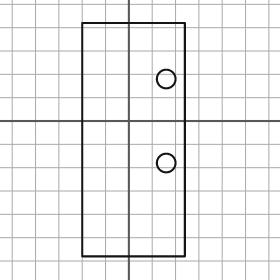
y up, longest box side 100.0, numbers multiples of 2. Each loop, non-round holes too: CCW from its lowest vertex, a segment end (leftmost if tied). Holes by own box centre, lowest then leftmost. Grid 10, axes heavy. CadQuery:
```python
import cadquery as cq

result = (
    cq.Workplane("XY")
    .moveTo(-20.0, -58.0)
    .lineTo(24.0, -58.0)
    .lineTo(24.0, 42.0)
    .lineTo(-20.0, 42.0)
    .close()
    .moveTo(16.0, -18.0)
    .circle(4.0)
    .moveTo(16.0, 18.0)
    .circle(4.0)
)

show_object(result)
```